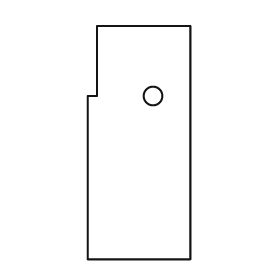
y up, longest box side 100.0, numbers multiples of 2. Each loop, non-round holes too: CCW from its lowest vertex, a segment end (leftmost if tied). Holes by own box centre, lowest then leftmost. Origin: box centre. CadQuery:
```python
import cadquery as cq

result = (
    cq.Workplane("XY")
    .moveTo(-22.0, -50.0)
    .lineTo(22.0, -50.0)
    .lineTo(22.0, 50.0)
    .lineTo(-18.0, 50.0)
    .lineTo(-18.0, 20.0)
    .lineTo(-22.0, 20.0)
    .close()
    .moveTo(6.0, 20.0)
    .circle(4.0)
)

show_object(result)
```